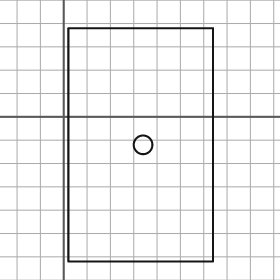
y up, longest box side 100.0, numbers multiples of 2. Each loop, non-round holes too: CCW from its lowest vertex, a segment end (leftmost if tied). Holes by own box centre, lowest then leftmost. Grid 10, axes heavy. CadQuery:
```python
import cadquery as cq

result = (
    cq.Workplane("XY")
    .moveTo(2.0, -62.0)
    .lineTo(64.0, -62.0)
    .lineTo(64.0, 38.0)
    .lineTo(2.0, 38.0)
    .close()
    .moveTo(34.0, -12.0)
    .circle(4.0)
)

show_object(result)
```